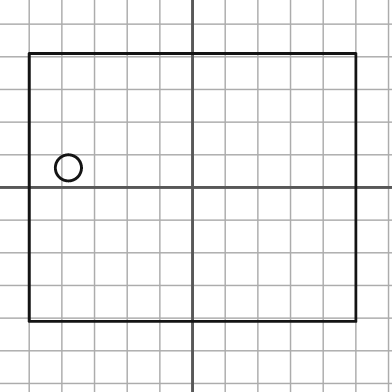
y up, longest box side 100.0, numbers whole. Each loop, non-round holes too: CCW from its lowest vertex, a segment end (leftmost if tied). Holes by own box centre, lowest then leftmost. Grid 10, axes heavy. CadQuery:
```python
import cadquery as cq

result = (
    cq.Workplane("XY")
    .moveTo(-50.0, -41.0)
    .lineTo(50.0, -41.0)
    .lineTo(50.0, 41.0)
    .lineTo(-50.0, 41.0)
    .close()
    .moveTo(-38.0, 6.0)
    .circle(4.0)
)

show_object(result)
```